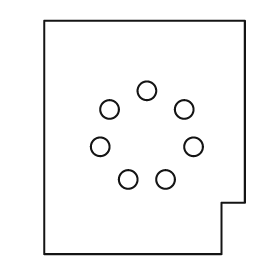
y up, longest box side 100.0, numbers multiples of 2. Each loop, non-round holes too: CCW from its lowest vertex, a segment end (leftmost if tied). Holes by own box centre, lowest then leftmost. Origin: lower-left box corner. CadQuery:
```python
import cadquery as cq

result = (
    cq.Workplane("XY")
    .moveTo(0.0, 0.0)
    .lineTo(76.0, 0.0)
    .lineTo(76.0, 22.0)
    .lineTo(86.0, 22.0)
    .lineTo(86.0, 100.0)
    .lineTo(0.0, 100.0)
    .close()
    .moveTo(36.0, 32.0)
    .circle(4.0)
    .moveTo(52.0, 32.0)
    .circle(4.0)
    .moveTo(24.0, 46.0)
    .circle(4.0)
    .moveTo(64.0, 46.0)
    .circle(4.0)
    .moveTo(28.0, 62.0)
    .circle(4.0)
    .moveTo(60.0, 62.0)
    .circle(4.0)
    .moveTo(44.0, 70.0)
    .circle(4.0)
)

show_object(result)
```